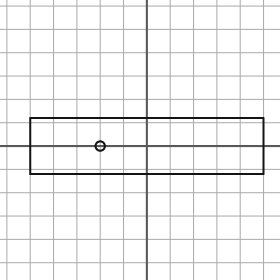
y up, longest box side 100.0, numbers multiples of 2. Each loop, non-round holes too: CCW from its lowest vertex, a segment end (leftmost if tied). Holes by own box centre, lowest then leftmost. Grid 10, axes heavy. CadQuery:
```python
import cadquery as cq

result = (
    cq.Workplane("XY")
    .moveTo(-50.0, -12.0)
    .lineTo(50.0, -12.0)
    .lineTo(50.0, 12.0)
    .lineTo(-50.0, 12.0)
    .close()
    .moveTo(-20.0, 0.0)
    .circle(2.0)
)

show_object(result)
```